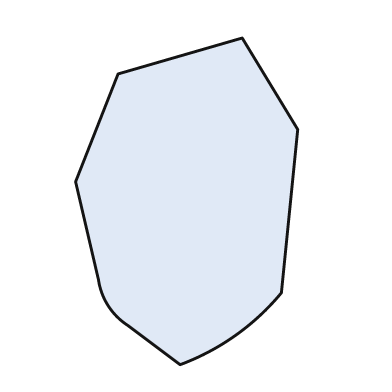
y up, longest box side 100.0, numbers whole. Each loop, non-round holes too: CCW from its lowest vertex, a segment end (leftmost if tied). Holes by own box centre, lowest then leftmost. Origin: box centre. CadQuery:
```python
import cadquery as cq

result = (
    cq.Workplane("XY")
    .moveTo(-2.0, -50.0)
    .threePointArc((15.0, -41.0), (29.0, -28.0))
    .lineTo(34.0, 22.0)
    .lineTo(17.0, 50.0)
    .lineTo(-21.0, 39.0)
    .lineTo(-34.0, 6.0)
    .lineTo(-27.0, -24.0)
    .threePointArc((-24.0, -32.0), (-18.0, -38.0))
    .close()
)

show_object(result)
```